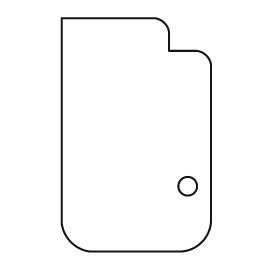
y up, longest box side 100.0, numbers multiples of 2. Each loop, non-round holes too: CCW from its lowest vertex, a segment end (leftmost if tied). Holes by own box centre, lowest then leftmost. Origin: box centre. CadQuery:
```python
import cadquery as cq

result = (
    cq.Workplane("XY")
    .moveTo(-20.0, -50.0)
    .lineTo(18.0, -50.0)
    .threePointArc((28.0, -46.0), (32.0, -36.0))
    .lineTo(32.0, 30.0)
    .threePointArc((30.0, 34.0), (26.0, 36.0))
    .lineTo(14.0, 36.0)
    .lineTo(14.0, 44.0)
    .threePointArc((12.0, 48.0), (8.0, 50.0))
    .lineTo(-32.0, 50.0)
    .lineTo(-32.0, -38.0)
    .threePointArc((-28.0, -46.0), (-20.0, -50.0))
    .close()
    .moveTo(22.0, -22.0)
    .circle(4.0)
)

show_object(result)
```